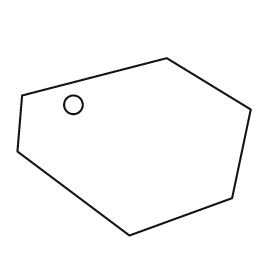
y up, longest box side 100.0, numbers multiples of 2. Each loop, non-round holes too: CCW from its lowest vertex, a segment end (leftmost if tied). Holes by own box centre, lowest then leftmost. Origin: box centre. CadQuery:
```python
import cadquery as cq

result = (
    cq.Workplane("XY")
    .moveTo(-2.0, -38.0)
    .lineTo(42.0, -22.0)
    .lineTo(50.0, 16.0)
    .lineTo(14.0, 38.0)
    .lineTo(-48.0, 22.0)
    .lineTo(-50.0, -2.0)
    .close()
    .moveTo(-26.0, 18.0)
    .circle(4.0)
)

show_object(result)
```